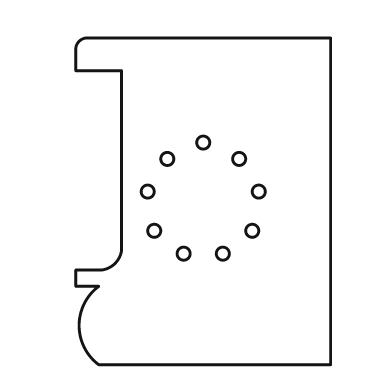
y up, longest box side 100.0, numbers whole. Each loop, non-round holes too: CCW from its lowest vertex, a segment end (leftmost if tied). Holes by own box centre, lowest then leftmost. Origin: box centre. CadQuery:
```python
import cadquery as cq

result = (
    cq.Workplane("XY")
    .moveTo(-32.0, -50.0)
    .lineTo(39.0, -50.0)
    .lineTo(39.0, 50.0)
    .lineTo(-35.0, 50.0)
    .threePointArc((-38.0, 49.0), (-39.0, 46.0))
    .lineTo(-39.0, 40.0)
    .lineTo(-25.0, 40.0)
    .lineTo(-25.0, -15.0)
    .threePointArc((-27.0, -19.0), (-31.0, -21.0))
    .lineTo(-39.0, -21.0)
    .lineTo(-39.0, -26.0)
    .lineTo(-32.0, -26.0)
    .threePointArc((-38.0, -38.0), (-32.0, -50.0))
    .close()
    .moveTo(-6.0, -16.0)
    .circle(2.0)
    .moveTo(6.0, -16.0)
    .circle(2.0)
    .moveTo(-15.0, -9.0)
    .circle(2.0)
    .moveTo(15.0, -9.0)
    .circle(2.0)
    .moveTo(-17.0, 3.0)
    .circle(2.0)
    .moveTo(17.0, 3.0)
    .circle(2.0)
    .moveTo(-11.0, 13.0)
    .circle(2.0)
    .moveTo(11.0, 13.0)
    .circle(2.0)
    .moveTo(0.0, 18.0)
    .circle(2.0)
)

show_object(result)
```